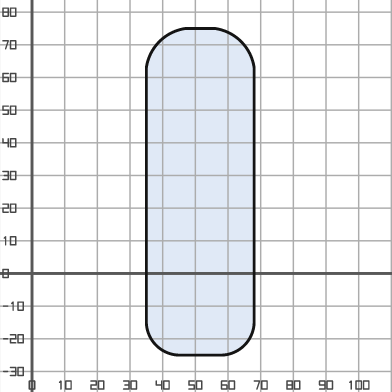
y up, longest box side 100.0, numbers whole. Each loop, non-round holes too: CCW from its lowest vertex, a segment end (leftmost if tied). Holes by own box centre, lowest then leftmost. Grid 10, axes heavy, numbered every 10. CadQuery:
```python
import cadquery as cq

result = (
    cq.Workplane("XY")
    .moveTo(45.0, -25.0)
    .lineTo(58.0, -25.0)
    .threePointArc((65.0, -22.0), (68.0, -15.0))
    .lineTo(68.0, 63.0)
    .threePointArc((64.0, 71.0), (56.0, 75.0))
    .lineTo(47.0, 75.0)
    .threePointArc((39.0, 71.0), (35.0, 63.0))
    .lineTo(35.0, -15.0)
    .threePointArc((38.0, -22.0), (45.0, -25.0))
    .close()
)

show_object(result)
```